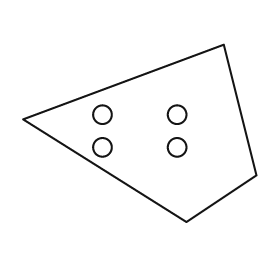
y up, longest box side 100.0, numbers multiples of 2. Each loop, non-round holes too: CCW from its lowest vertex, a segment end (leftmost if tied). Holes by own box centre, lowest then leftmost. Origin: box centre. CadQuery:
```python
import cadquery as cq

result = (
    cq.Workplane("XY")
    .moveTo(20.0, -38.0)
    .lineTo(50.0, -18.0)
    .lineTo(36.0, 38.0)
    .lineTo(-50.0, 6.0)
    .close()
    .moveTo(-16.0, -6.0)
    .circle(4.0)
    .moveTo(16.0, -6.0)
    .circle(4.0)
    .moveTo(-16.0, 8.0)
    .circle(4.0)
    .moveTo(16.0, 8.0)
    .circle(4.0)
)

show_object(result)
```